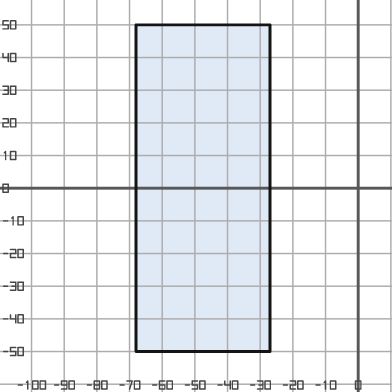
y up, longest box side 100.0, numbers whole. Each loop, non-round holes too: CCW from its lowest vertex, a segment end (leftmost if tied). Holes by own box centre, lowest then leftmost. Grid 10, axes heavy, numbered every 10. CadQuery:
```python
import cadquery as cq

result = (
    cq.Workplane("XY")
    .moveTo(-68.0, -50.0)
    .lineTo(-27.0, -50.0)
    .lineTo(-27.0, 50.0)
    .lineTo(-68.0, 50.0)
    .close()
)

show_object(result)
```